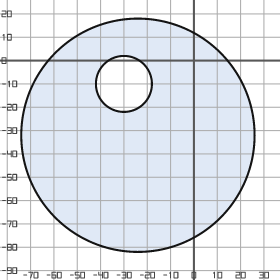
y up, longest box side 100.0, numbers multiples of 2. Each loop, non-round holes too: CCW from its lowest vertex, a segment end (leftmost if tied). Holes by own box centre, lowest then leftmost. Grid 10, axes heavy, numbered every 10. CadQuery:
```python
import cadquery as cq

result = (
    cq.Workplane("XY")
    .moveTo(-24.0, -32.0)
    .circle(50.0)
    .moveTo(-30.0, -10.0)
    .circle(12.0)
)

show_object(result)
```